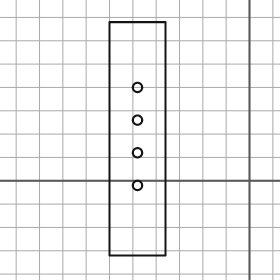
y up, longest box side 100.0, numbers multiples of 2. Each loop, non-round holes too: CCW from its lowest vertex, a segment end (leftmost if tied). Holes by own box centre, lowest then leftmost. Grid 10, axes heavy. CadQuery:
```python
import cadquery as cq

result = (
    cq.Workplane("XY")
    .moveTo(-60.0, -32.0)
    .lineTo(-36.0, -32.0)
    .lineTo(-36.0, 68.0)
    .lineTo(-60.0, 68.0)
    .close()
    .moveTo(-48.0, -2.0)
    .circle(2.0)
    .moveTo(-48.0, 12.0)
    .circle(2.0)
    .moveTo(-48.0, 26.0)
    .circle(2.0)
    .moveTo(-48.0, 40.0)
    .circle(2.0)
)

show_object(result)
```